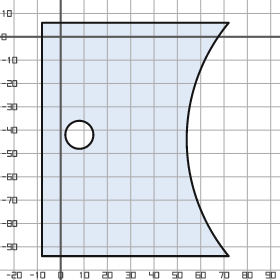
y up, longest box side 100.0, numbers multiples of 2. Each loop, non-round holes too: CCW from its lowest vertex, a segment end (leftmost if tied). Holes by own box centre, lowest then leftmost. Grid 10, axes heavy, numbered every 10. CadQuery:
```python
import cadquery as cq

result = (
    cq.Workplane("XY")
    .moveTo(-8.0, -94.0)
    .lineTo(72.0, -94.0)
    .threePointArc((54.0, -44.0), (72.0, 6.0))
    .lineTo(-8.0, 6.0)
    .close()
    .moveTo(8.0, -42.0)
    .circle(6.0)
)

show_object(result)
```